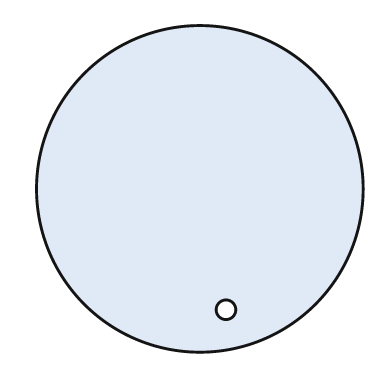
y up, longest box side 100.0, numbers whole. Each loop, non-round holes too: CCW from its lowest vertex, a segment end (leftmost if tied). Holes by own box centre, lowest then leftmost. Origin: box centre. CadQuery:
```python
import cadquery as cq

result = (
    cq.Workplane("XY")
    .moveTo(0.0, 0.0)
    .circle(50.0)
    .moveTo(8.0, -37.0)
    .circle(3.0)
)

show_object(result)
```